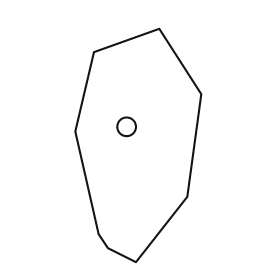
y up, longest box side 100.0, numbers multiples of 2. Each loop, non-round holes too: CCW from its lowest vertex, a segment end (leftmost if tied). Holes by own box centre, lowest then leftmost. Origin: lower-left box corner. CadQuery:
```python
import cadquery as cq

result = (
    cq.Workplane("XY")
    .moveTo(26.0, 0.0)
    .lineTo(48.0, 28.0)
    .lineTo(54.0, 72.0)
    .lineTo(36.0, 100.0)
    .lineTo(8.0, 90.0)
    .lineTo(0.0, 56.0)
    .lineTo(10.0, 12.0)
    .lineTo(14.0, 6.0)
    .close()
    .moveTo(22.0, 58.0)
    .circle(4.0)
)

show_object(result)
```